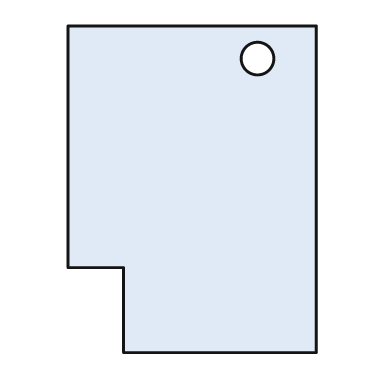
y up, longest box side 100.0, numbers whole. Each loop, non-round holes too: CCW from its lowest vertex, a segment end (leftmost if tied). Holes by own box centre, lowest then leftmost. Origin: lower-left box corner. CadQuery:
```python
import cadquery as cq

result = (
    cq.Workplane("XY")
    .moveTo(17.0, 0.0)
    .lineTo(76.0, 0.0)
    .lineTo(76.0, 100.0)
    .lineTo(0.0, 100.0)
    .lineTo(0.0, 26.0)
    .lineTo(17.0, 26.0)
    .close()
    .moveTo(58.0, 90.0)
    .circle(5.0)
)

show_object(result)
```